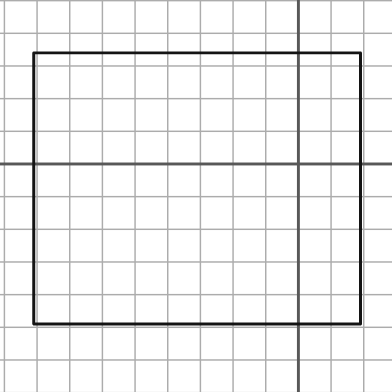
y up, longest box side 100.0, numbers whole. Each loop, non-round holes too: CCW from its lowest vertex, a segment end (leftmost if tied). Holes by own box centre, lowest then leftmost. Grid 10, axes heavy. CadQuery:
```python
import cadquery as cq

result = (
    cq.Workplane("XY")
    .moveTo(-81.0, -49.0)
    .lineTo(19.0, -49.0)
    .lineTo(19.0, 34.0)
    .lineTo(-81.0, 34.0)
    .close()
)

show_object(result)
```